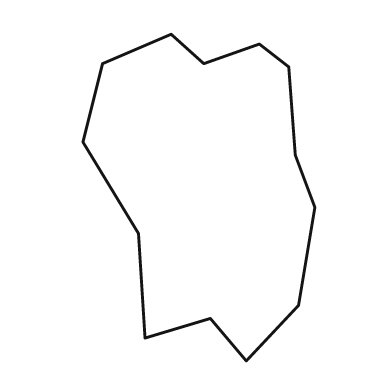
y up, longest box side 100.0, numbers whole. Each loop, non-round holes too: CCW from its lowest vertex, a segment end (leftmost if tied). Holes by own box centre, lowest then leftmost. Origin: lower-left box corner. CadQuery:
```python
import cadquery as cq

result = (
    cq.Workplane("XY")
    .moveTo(50.0, 0.0)
    .lineTo(66.0, 17.0)
    .lineTo(71.0, 47.0)
    .lineTo(65.0, 63.0)
    .lineTo(63.0, 90.0)
    .lineTo(54.0, 97.0)
    .lineTo(37.0, 91.0)
    .lineTo(27.0, 100.0)
    .lineTo(6.0, 91.0)
    .lineTo(0.0, 67.0)
    .lineTo(17.0, 39.0)
    .lineTo(19.0, 7.0)
    .lineTo(39.0, 13.0)
    .close()
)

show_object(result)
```